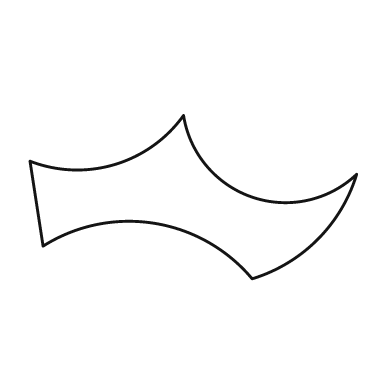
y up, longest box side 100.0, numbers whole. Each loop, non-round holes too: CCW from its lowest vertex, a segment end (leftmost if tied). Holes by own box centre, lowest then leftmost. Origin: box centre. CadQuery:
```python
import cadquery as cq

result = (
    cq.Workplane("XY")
    .moveTo(18.0, -25.0)
    .threePointArc((38.0, -13.0), (50.0, 7.0))
    .threePointArc((18.0, 0.0), (-3.0, 25.0))
    .threePointArc((-24.0, 10.0), (-50.0, 11.0))
    .lineTo(-46.0, -15.0)
    .threePointArc((-12.0, -8.0), (18.0, -25.0))
    .close()
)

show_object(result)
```